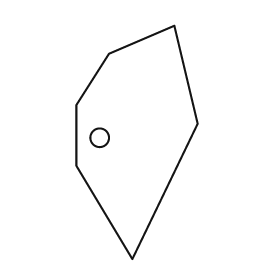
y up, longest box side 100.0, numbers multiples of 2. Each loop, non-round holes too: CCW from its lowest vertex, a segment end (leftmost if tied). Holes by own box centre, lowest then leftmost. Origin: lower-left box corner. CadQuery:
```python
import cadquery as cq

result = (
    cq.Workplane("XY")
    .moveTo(24.0, 0.0)
    .lineTo(52.0, 58.0)
    .lineTo(42.0, 100.0)
    .lineTo(14.0, 88.0)
    .lineTo(0.0, 66.0)
    .lineTo(0.0, 40.0)
    .close()
    .moveTo(10.0, 52.0)
    .circle(4.0)
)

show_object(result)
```